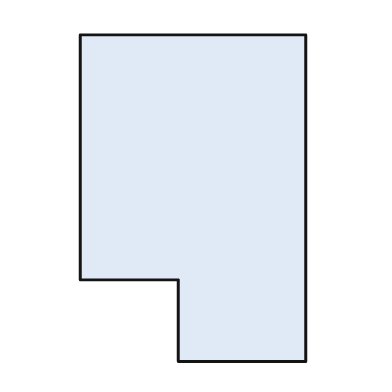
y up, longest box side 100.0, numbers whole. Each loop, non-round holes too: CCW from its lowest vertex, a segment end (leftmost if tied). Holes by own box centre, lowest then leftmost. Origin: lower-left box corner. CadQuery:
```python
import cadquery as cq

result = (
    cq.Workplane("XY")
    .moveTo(30.0, 0.0)
    .lineTo(69.0, 0.0)
    .lineTo(69.0, 100.0)
    .lineTo(0.0, 100.0)
    .lineTo(0.0, 25.0)
    .lineTo(30.0, 25.0)
    .close()
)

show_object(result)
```